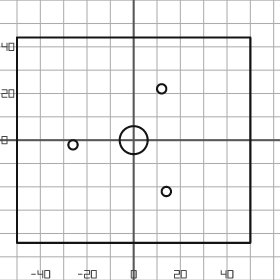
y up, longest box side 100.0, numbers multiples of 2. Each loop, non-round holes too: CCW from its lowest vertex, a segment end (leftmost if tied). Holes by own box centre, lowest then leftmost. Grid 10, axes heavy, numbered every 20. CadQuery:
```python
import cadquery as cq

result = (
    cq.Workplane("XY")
    .moveTo(-50.0, -44.0)
    .lineTo(50.0, -44.0)
    .lineTo(50.0, 44.0)
    .lineTo(-50.0, 44.0)
    .close()
    .moveTo(14.0, -22.0)
    .circle(2.0)
    .moveTo(-26.0, -2.0)
    .circle(2.0)
    .moveTo(0.0, 0.0)
    .circle(6.0)
    .moveTo(12.0, 22.0)
    .circle(2.0)
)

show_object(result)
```